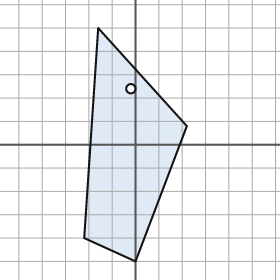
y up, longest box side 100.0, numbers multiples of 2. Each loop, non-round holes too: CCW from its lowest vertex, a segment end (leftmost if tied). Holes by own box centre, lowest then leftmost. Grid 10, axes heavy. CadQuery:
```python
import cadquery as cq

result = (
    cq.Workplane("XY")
    .moveTo(0.0, -50.0)
    .lineTo(22.0, 8.0)
    .lineTo(-16.0, 50.0)
    .lineTo(-22.0, -40.0)
    .close()
    .moveTo(-2.0, 24.0)
    .circle(2.0)
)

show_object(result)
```